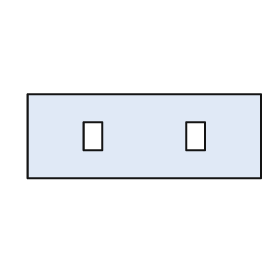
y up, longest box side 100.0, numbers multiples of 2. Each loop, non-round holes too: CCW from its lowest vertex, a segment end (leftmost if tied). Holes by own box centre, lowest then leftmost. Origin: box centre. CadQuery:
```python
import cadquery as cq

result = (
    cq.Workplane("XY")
    .moveTo(-50.0, -18.0)
    .lineTo(50.0, -18.0)
    .lineTo(50.0, 18.0)
    .lineTo(-50.0, 18.0)
    .close()
    .moveTo(-26.0, -6.0)
    .lineTo(-18.0, -6.0)
    .lineTo(-18.0, 6.0)
    .lineTo(-26.0, 6.0)
    .close()
    .moveTo(18.0, -6.0)
    .lineTo(26.0, -6.0)
    .lineTo(26.0, 6.0)
    .lineTo(18.0, 6.0)
    .close()
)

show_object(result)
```